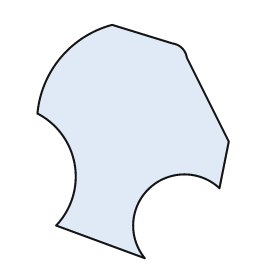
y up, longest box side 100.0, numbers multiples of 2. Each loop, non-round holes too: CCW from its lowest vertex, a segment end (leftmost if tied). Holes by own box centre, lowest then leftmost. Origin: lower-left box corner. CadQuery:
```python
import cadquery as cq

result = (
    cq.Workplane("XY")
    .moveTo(46.0, 0.0)
    .threePointArc((48.0, 30.0), (78.0, 30.0))
    .lineTo(82.0, 50.0)
    .lineTo(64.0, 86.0)
    .threePointArc((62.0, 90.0), (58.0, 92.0))
    .lineTo(32.0, 100.0)
    .threePointArc((10.0, 86.0), (0.0, 62.0))
    .threePointArc((16.0, 40.0), (8.0, 14.0))
    .close()
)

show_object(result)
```